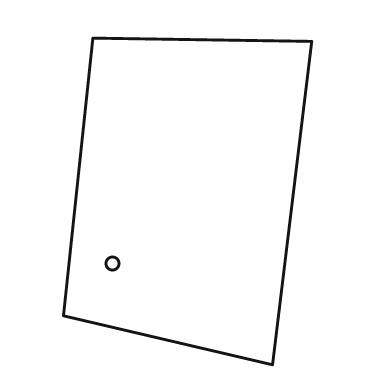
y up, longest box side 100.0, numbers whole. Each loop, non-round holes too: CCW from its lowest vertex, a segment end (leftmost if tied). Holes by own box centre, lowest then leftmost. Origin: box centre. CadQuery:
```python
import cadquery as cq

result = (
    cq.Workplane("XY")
    .moveTo(26.0, -50.0)
    .lineTo(38.0, 49.0)
    .lineTo(-29.0, 50.0)
    .lineTo(-38.0, -35.0)
    .close()
    .moveTo(-23.0, -19.0)
    .circle(2.0)
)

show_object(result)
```